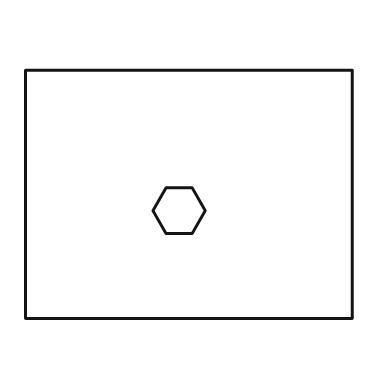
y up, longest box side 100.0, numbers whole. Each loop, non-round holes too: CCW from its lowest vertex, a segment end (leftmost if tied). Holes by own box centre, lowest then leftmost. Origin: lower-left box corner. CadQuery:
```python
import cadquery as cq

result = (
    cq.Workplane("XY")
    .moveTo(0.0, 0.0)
    .lineTo(100.0, 0.0)
    .lineTo(100.0, 76.0)
    .lineTo(0.0, 76.0)
    .close()
    .moveTo(43.0, 26.0)
    .lineTo(51.0, 26.0)
    .lineTo(55.0, 33.0)
    .lineTo(51.0, 40.0)
    .lineTo(43.0, 40.0)
    .lineTo(39.0, 33.0)
    .close()
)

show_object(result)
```